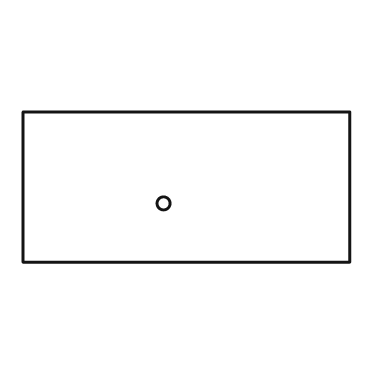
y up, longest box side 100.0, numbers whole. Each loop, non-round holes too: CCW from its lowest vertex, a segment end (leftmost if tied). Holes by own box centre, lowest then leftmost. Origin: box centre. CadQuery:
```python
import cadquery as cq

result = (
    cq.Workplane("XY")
    .moveTo(-50.0, -23.0)
    .lineTo(50.0, -23.0)
    .lineTo(50.0, 23.0)
    .lineTo(-50.0, 23.0)
    .close()
    .moveTo(-7.0, -5.0)
    .circle(2.0)
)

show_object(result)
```